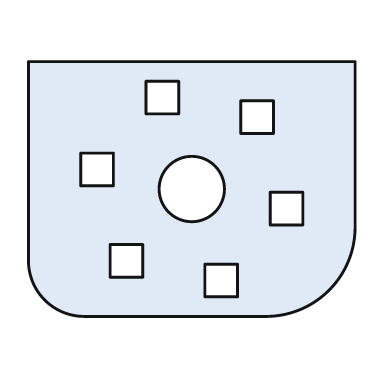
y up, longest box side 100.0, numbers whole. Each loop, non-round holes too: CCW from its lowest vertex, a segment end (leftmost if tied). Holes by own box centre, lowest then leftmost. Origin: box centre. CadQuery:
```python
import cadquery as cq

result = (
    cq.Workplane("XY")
    .moveTo(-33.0, -39.0)
    .lineTo(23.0, -39.0)
    .threePointArc((42.0, -31.0), (50.0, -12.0))
    .lineTo(50.0, 39.0)
    .lineTo(-50.0, 39.0)
    .lineTo(-50.0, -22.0)
    .threePointArc((-45.0, -34.0), (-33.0, -39.0))
    .close()
    .moveTo(4.0, -33.0)
    .lineTo(14.0, -33.0)
    .lineTo(14.0, -23.0)
    .lineTo(4.0, -23.0)
    .close()
    .moveTo(-25.0, -27.0)
    .lineTo(-15.0, -27.0)
    .lineTo(-15.0, -17.0)
    .lineTo(-25.0, -17.0)
    .close()
    .moveTo(24.0, -11.0)
    .lineTo(34.0, -11.0)
    .lineTo(34.0, -1.0)
    .lineTo(24.0, -1.0)
    .close()
    .moveTo(0.0, 0.0)
    .circle(10.0)
    .moveTo(-34.0, 1.0)
    .lineTo(-24.0, 1.0)
    .lineTo(-24.0, 11.0)
    .lineTo(-34.0, 11.0)
    .close()
    .moveTo(15.0, 17.0)
    .lineTo(25.0, 17.0)
    .lineTo(25.0, 27.0)
    .lineTo(15.0, 27.0)
    .close()
    .moveTo(-14.0, 23.0)
    .lineTo(-4.0, 23.0)
    .lineTo(-4.0, 33.0)
    .lineTo(-14.0, 33.0)
    .close()
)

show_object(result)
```